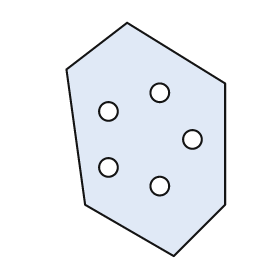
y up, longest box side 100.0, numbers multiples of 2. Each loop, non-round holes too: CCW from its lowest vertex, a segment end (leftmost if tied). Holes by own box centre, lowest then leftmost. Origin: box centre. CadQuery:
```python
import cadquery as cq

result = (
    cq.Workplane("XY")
    .moveTo(12.0, -50.0)
    .lineTo(34.0, -28.0)
    .lineTo(34.0, 24.0)
    .lineTo(-8.0, 50.0)
    .lineTo(-34.0, 30.0)
    .lineTo(-26.0, -28.0)
    .close()
    .moveTo(6.0, -20.0)
    .circle(4.0)
    .moveTo(-16.0, -12.0)
    .circle(4.0)
    .moveTo(20.0, 0.0)
    .circle(4.0)
    .moveTo(-16.0, 12.0)
    .circle(4.0)
    .moveTo(6.0, 20.0)
    .circle(4.0)
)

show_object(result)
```